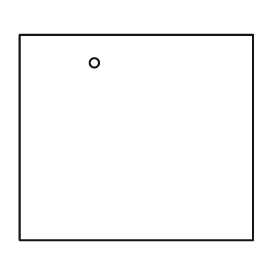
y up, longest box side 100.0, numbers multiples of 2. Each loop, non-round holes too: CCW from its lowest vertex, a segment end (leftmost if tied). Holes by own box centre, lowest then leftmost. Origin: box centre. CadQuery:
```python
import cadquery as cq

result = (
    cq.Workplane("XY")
    .moveTo(-50.0, -44.0)
    .lineTo(50.0, -44.0)
    .lineTo(50.0, 44.0)
    .lineTo(-50.0, 44.0)
    .close()
    .moveTo(-18.0, 32.0)
    .circle(2.0)
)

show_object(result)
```